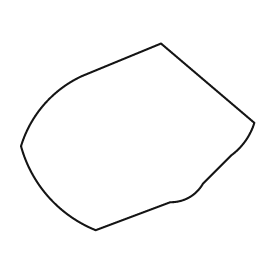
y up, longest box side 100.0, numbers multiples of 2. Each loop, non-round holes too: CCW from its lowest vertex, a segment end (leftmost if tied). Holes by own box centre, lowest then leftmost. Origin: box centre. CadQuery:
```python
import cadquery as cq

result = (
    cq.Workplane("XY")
    .moveTo(-18.0, -40.0)
    .lineTo(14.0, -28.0)
    .threePointArc((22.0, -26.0), (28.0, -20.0))
    .lineTo(40.0, -8.0)
    .threePointArc((46.0, -2.0), (50.0, 6.0))
    .lineTo(10.0, 40.0)
    .lineTo(-24.0, 26.0)
    .threePointArc((-40.0, 14.0), (-50.0, -4.0))
    .threePointArc((-38.0, -26.0), (-18.0, -40.0))
    .close()
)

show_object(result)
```